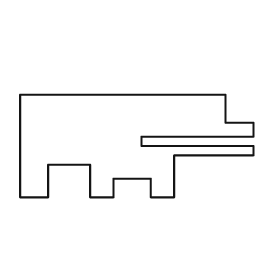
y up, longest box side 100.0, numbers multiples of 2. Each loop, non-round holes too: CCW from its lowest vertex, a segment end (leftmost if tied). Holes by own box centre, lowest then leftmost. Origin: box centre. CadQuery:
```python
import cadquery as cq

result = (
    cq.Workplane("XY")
    .moveTo(-50.0, -22.0)
    .lineTo(-38.0, -22.0)
    .lineTo(-38.0, -8.0)
    .lineTo(-20.0, -8.0)
    .lineTo(-20.0, -22.0)
    .lineTo(-10.0, -22.0)
    .lineTo(-10.0, -14.0)
    .lineTo(6.0, -14.0)
    .lineTo(6.0, -22.0)
    .lineTo(16.0, -22.0)
    .lineTo(16.0, -4.0)
    .lineTo(50.0, -4.0)
    .lineTo(50.0, 0.0)
    .lineTo(2.0, 0.0)
    .lineTo(2.0, 4.0)
    .lineTo(50.0, 4.0)
    .lineTo(50.0, 10.0)
    .lineTo(38.0, 10.0)
    .lineTo(38.0, 22.0)
    .lineTo(-50.0, 22.0)
    .close()
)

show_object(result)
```